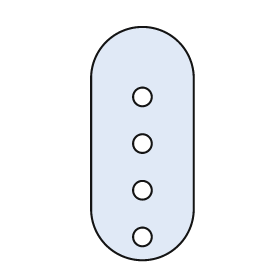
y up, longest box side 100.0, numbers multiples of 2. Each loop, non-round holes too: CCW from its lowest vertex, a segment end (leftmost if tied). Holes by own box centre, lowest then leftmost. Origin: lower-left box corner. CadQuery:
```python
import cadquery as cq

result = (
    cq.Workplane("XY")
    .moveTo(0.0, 22.0)
    .threePointArc((22.0, 0.0), (44.0, 22.0))
    .lineTo(44.0, 78.0)
    .threePointArc((22.0, 100.0), (0.0, 78.0))
    .close()
    .moveTo(22.0, 10.0)
    .circle(4.0)
    .moveTo(22.0, 30.0)
    .circle(4.0)
    .moveTo(22.0, 50.0)
    .circle(4.0)
    .moveTo(22.0, 70.0)
    .circle(4.0)
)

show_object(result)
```